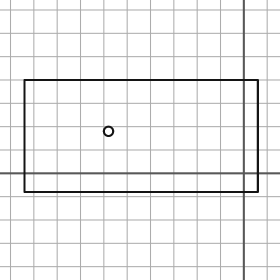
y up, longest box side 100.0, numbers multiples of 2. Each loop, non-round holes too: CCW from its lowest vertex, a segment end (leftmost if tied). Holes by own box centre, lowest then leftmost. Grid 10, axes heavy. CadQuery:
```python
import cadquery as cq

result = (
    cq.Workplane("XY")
    .moveTo(-94.0, -8.0)
    .lineTo(6.0, -8.0)
    .lineTo(6.0, 40.0)
    .lineTo(-94.0, 40.0)
    .close()
    .moveTo(-58.0, 18.0)
    .circle(2.0)
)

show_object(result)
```